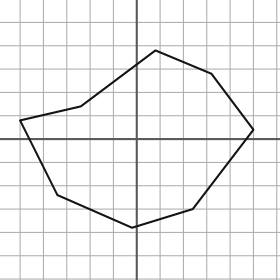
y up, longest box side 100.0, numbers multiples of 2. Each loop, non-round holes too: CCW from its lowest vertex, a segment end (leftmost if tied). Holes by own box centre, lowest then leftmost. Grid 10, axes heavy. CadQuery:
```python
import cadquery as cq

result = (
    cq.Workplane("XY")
    .moveTo(-2.0, -38.0)
    .lineTo(24.0, -30.0)
    .lineTo(50.0, 4.0)
    .lineTo(32.0, 28.0)
    .lineTo(8.0, 38.0)
    .lineTo(-24.0, 14.0)
    .lineTo(-50.0, 8.0)
    .lineTo(-34.0, -24.0)
    .close()
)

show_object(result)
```